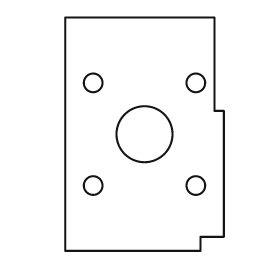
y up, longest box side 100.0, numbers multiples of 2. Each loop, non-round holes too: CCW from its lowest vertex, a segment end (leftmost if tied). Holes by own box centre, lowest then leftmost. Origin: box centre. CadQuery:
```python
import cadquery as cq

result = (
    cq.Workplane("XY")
    .moveTo(-34.0, -50.0)
    .lineTo(24.0, -50.0)
    .lineTo(24.0, -44.0)
    .lineTo(34.0, -44.0)
    .lineTo(34.0, 10.0)
    .lineTo(30.0, 10.0)
    .lineTo(30.0, 50.0)
    .lineTo(-34.0, 50.0)
    .close()
    .moveTo(-22.0, -22.0)
    .circle(4.0)
    .moveTo(22.0, -22.0)
    .circle(4.0)
    .moveTo(0.0, 0.0)
    .circle(12.0)
    .moveTo(-22.0, 22.0)
    .circle(4.0)
    .moveTo(22.0, 22.0)
    .circle(4.0)
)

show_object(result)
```